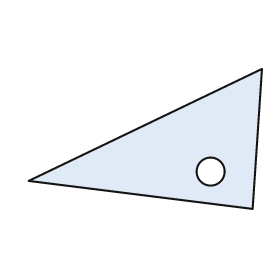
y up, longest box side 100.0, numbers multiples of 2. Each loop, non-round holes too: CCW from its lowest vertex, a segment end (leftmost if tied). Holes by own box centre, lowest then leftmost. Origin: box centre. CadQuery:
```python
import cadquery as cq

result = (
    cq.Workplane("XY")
    .moveTo(46.0, -30.0)
    .lineTo(50.0, 30.0)
    .lineTo(-50.0, -18.0)
    .close()
    .moveTo(28.0, -14.0)
    .circle(6.0)
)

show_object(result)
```